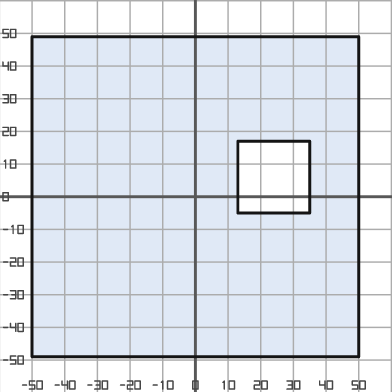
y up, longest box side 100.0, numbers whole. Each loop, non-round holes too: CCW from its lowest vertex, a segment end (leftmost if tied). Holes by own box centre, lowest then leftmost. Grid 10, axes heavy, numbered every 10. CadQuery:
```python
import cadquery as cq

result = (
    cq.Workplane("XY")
    .moveTo(-50.0, -49.0)
    .lineTo(50.0, -49.0)
    .lineTo(50.0, 49.0)
    .lineTo(-50.0, 49.0)
    .close()
    .moveTo(13.0, -5.0)
    .lineTo(35.0, -5.0)
    .lineTo(35.0, 17.0)
    .lineTo(13.0, 17.0)
    .close()
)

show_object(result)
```